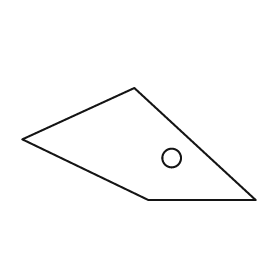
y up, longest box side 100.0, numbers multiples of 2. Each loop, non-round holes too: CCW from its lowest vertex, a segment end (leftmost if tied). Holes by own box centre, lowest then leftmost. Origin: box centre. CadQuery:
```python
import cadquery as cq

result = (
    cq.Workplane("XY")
    .moveTo(4.0, -24.0)
    .lineTo(50.0, -24.0)
    .lineTo(-2.0, 24.0)
    .lineTo(-50.0, 2.0)
    .close()
    .moveTo(14.0, -6.0)
    .circle(4.0)
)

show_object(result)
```